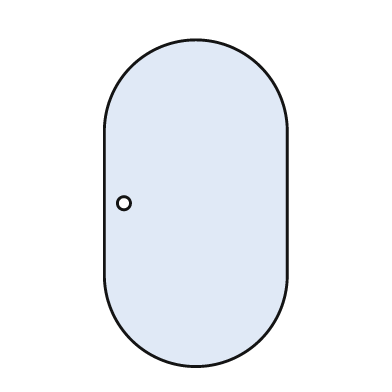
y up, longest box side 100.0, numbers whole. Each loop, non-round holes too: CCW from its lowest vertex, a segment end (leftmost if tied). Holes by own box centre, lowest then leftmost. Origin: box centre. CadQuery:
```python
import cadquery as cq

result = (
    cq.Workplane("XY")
    .moveTo(-28.0, -22.0)
    .threePointArc((0.0, -50.0), (28.0, -22.0))
    .lineTo(28.0, 22.0)
    .threePointArc((0.0, 50.0), (-28.0, 22.0))
    .close()
    .moveTo(-22.0, 0.0)
    .circle(2.0)
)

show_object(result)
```